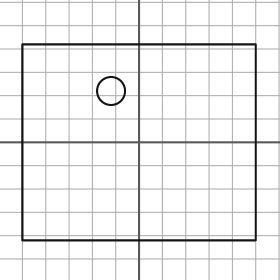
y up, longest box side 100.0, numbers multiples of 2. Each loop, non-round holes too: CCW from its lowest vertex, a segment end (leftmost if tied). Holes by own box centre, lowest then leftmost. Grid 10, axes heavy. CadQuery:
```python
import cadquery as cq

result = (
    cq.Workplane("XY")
    .moveTo(-50.0, -42.0)
    .lineTo(50.0, -42.0)
    .lineTo(50.0, 42.0)
    .lineTo(-50.0, 42.0)
    .close()
    .moveTo(-12.0, 22.0)
    .circle(6.0)
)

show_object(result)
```